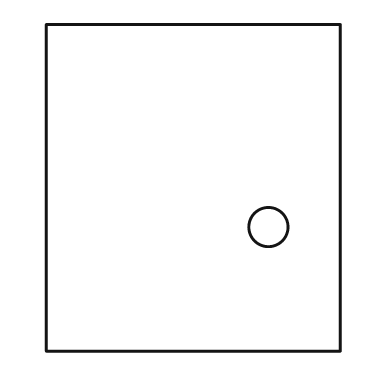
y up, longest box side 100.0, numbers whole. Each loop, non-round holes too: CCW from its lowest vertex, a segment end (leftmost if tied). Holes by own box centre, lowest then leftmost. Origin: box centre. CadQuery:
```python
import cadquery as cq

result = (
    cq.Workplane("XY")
    .moveTo(-45.0, -50.0)
    .lineTo(45.0, -50.0)
    .lineTo(45.0, 50.0)
    .lineTo(-45.0, 50.0)
    .close()
    .moveTo(23.0, -12.0)
    .circle(6.0)
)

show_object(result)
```